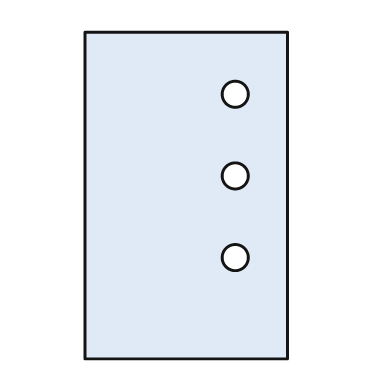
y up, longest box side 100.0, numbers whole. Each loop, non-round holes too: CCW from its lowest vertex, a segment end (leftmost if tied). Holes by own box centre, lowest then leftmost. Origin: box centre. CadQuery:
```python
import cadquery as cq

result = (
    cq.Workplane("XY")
    .moveTo(-31.0, -50.0)
    .lineTo(31.0, -50.0)
    .lineTo(31.0, 50.0)
    .lineTo(-31.0, 50.0)
    .close()
    .moveTo(15.0, -19.0)
    .circle(4.0)
    .moveTo(15.0, 6.0)
    .circle(4.0)
    .moveTo(15.0, 31.0)
    .circle(4.0)
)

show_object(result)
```